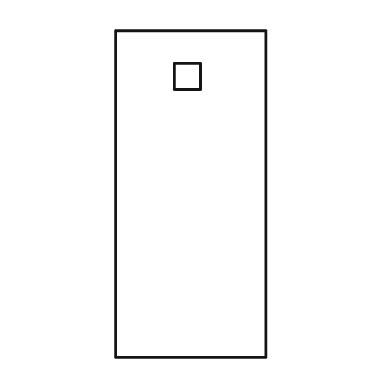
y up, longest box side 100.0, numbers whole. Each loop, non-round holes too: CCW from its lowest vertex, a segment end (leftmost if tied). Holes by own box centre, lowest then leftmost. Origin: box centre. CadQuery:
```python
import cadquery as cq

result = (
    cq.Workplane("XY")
    .moveTo(-23.0, -50.0)
    .lineTo(23.0, -50.0)
    .lineTo(23.0, 50.0)
    .lineTo(-23.0, 50.0)
    .close()
    .moveTo(-5.0, 32.0)
    .lineTo(3.0, 32.0)
    .lineTo(3.0, 40.0)
    .lineTo(-5.0, 40.0)
    .close()
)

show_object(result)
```